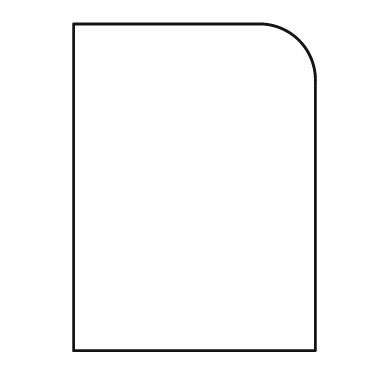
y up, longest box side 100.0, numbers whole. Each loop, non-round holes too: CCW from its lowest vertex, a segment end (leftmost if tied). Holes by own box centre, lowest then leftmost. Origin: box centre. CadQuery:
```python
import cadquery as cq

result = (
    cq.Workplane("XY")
    .moveTo(-37.0, -50.0)
    .lineTo(37.0, -50.0)
    .lineTo(37.0, 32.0)
    .threePointArc((32.0, 45.0), (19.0, 50.0))
    .lineTo(-37.0, 50.0)
    .close()
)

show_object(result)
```